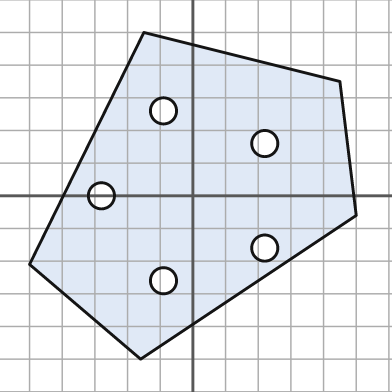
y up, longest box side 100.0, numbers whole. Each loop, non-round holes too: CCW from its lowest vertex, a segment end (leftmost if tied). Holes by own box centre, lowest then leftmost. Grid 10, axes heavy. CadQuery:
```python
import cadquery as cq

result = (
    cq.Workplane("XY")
    .moveTo(-16.0, -50.0)
    .lineTo(50.0, -6.0)
    .lineTo(45.0, 35.0)
    .lineTo(-15.0, 50.0)
    .lineTo(-50.0, -21.0)
    .close()
    .moveTo(-9.0, -26.0)
    .circle(4.0)
    .moveTo(22.0, -16.0)
    .circle(4.0)
    .moveTo(-28.0, 0.0)
    .circle(4.0)
    .moveTo(22.0, 16.0)
    .circle(4.0)
    .moveTo(-9.0, 26.0)
    .circle(4.0)
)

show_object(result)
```